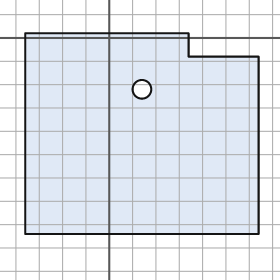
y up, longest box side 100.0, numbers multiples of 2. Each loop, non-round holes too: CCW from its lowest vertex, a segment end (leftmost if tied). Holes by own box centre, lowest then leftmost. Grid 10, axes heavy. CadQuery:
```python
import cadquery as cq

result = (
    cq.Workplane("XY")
    .moveTo(-36.0, -84.0)
    .lineTo(64.0, -84.0)
    .lineTo(64.0, -8.0)
    .lineTo(34.0, -8.0)
    .lineTo(34.0, 2.0)
    .lineTo(-36.0, 2.0)
    .close()
    .moveTo(14.0, -22.0)
    .circle(4.0)
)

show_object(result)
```